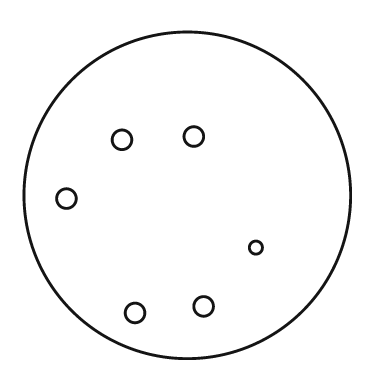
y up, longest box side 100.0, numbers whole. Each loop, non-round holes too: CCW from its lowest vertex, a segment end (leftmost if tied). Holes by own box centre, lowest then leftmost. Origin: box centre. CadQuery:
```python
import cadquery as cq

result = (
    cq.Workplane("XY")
    .moveTo(0.0, 0.0)
    .circle(50.0)
    .moveTo(-16.0, -36.0)
    .circle(3.0)
    .moveTo(5.0, -34.0)
    .circle(3.0)
    .moveTo(21.0, -16.0)
    .circle(2.0)
    .moveTo(-37.0, -1.0)
    .circle(3.0)
    .moveTo(-20.0, 17.0)
    .circle(3.0)
    .moveTo(2.0, 18.0)
    .circle(3.0)
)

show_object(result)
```